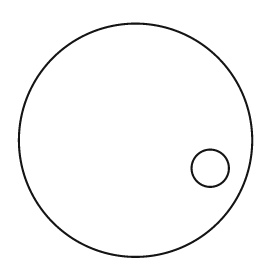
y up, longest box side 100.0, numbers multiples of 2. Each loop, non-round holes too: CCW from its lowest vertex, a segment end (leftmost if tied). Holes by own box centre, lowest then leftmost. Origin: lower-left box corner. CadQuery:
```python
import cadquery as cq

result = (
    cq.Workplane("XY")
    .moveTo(50.0, 50.0)
    .circle(50.0)
    .moveTo(82.0, 38.0)
    .circle(8.0)
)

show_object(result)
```